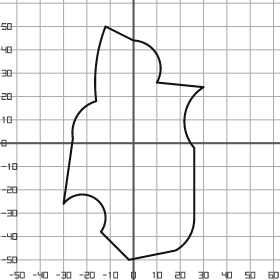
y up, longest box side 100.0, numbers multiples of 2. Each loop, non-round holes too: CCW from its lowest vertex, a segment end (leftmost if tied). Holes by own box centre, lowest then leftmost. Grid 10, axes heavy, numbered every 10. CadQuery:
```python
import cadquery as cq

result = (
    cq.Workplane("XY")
    .moveTo(-2.0, -50.0)
    .lineTo(18.0, -46.0)
    .threePointArc((24.0, -40.0), (26.0, -32.0))
    .lineTo(26.0, -2.0)
    .threePointArc((22.0, 12.0), (30.0, 24.0))
    .lineTo(10.0, 26.0)
    .threePointArc((10.0, 38.0), (0.0, 44.0))
    .lineTo(-12.0, 50.0)
    .threePointArc((-16.0, 34.0), (-16.0, 18.0))
    .threePointArc((-24.0, 12.0), (-26.0, 2.0))
    .lineTo(-30.0, -26.0)
    .threePointArc((-16.0, -24.0), (-14.0, -38.0))
    .close()
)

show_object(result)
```